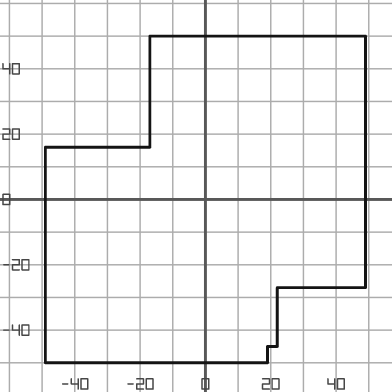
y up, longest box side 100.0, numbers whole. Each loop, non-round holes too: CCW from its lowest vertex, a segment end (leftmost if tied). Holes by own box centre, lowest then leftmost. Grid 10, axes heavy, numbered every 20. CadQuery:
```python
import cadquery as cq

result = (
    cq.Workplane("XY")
    .moveTo(-49.0, -50.0)
    .lineTo(19.0, -50.0)
    .lineTo(19.0, -45.0)
    .lineTo(22.0, -45.0)
    .lineTo(22.0, -27.0)
    .lineTo(49.0, -27.0)
    .lineTo(49.0, 50.0)
    .lineTo(-17.0, 50.0)
    .lineTo(-17.0, 16.0)
    .lineTo(-49.0, 16.0)
    .close()
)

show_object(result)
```